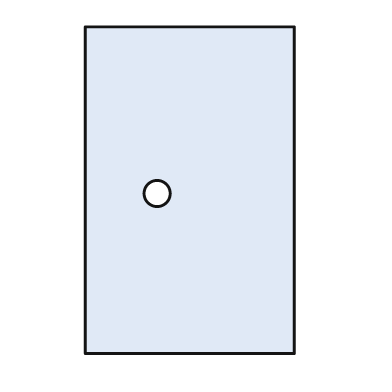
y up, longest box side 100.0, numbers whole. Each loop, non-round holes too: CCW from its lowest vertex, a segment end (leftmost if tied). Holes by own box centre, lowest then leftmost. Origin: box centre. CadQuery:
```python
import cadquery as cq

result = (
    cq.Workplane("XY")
    .moveTo(-32.0, -50.0)
    .lineTo(32.0, -50.0)
    .lineTo(32.0, 50.0)
    .lineTo(-32.0, 50.0)
    .close()
    .moveTo(-10.0, -1.0)
    .circle(4.0)
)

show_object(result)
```